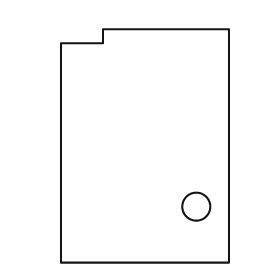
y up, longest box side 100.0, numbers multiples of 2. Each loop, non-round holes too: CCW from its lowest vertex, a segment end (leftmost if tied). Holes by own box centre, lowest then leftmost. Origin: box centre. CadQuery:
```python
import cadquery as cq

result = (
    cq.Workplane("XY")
    .moveTo(-36.0, -50.0)
    .lineTo(36.0, -50.0)
    .lineTo(36.0, 50.0)
    .lineTo(-18.0, 50.0)
    .lineTo(-18.0, 44.0)
    .lineTo(-36.0, 44.0)
    .close()
    .moveTo(22.0, -26.0)
    .circle(6.0)
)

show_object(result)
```